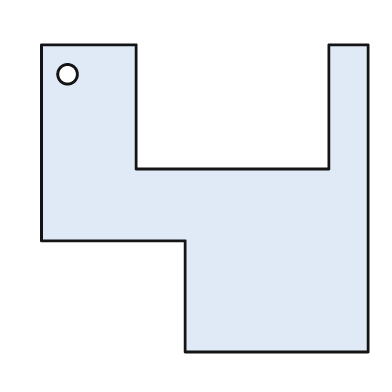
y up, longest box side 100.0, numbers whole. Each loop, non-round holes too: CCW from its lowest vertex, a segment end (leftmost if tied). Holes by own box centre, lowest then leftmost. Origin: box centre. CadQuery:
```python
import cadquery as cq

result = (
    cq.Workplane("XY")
    .moveTo(-6.0, -47.0)
    .lineTo(50.0, -47.0)
    .lineTo(50.0, 47.0)
    .lineTo(38.0, 47.0)
    .lineTo(38.0, 9.0)
    .lineTo(-21.0, 9.0)
    .lineTo(-21.0, 47.0)
    .lineTo(-50.0, 47.0)
    .lineTo(-50.0, -13.0)
    .lineTo(-6.0, -13.0)
    .close()
    .moveTo(-42.0, 38.0)
    .circle(3.0)
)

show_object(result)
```